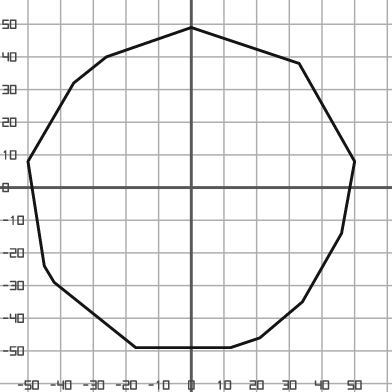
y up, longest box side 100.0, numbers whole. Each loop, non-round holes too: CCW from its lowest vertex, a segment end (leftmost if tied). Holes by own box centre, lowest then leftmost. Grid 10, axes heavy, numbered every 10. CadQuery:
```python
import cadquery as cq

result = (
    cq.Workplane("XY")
    .moveTo(-17.0, -49.0)
    .lineTo(12.0, -49.0)
    .lineTo(21.0, -46.0)
    .lineTo(34.0, -35.0)
    .lineTo(46.0, -14.0)
    .lineTo(50.0, 8.0)
    .lineTo(33.0, 38.0)
    .lineTo(0.0, 49.0)
    .lineTo(-26.0, 40.0)
    .lineTo(-36.0, 32.0)
    .lineTo(-50.0, 8.0)
    .lineTo(-45.0, -24.0)
    .lineTo(-42.0, -29.0)
    .close()
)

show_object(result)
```